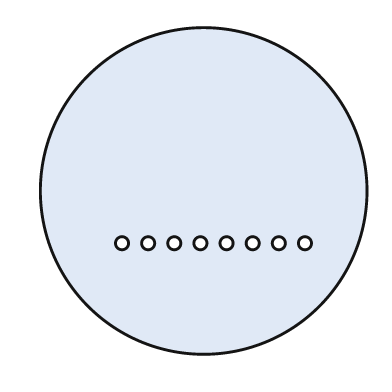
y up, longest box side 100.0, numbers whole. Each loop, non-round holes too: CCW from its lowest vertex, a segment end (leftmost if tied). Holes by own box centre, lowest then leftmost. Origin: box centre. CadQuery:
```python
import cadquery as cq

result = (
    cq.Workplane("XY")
    .moveTo(0.0, 0.0)
    .circle(50.0)
    .moveTo(-25.0, -16.0)
    .circle(2.0)
    .moveTo(-17.0, -16.0)
    .circle(2.0)
    .moveTo(-9.0, -16.0)
    .circle(2.0)
    .moveTo(-1.0, -16.0)
    .circle(2.0)
    .moveTo(7.0, -16.0)
    .circle(2.0)
    .moveTo(15.0, -16.0)
    .circle(2.0)
    .moveTo(23.0, -16.0)
    .circle(2.0)
    .moveTo(31.0, -16.0)
    .circle(2.0)
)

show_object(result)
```